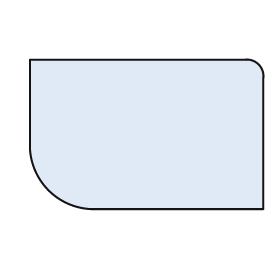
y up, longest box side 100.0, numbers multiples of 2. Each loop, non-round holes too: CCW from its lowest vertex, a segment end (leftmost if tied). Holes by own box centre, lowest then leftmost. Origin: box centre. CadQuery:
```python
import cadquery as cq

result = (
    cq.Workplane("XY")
    .moveTo(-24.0, -32.0)
    .lineTo(50.0, -32.0)
    .lineTo(50.0, 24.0)
    .threePointArc((48.0, 30.0), (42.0, 32.0))
    .lineTo(-50.0, 32.0)
    .lineTo(-50.0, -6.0)
    .threePointArc((-42.0, -24.0), (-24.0, -32.0))
    .close()
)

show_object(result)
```